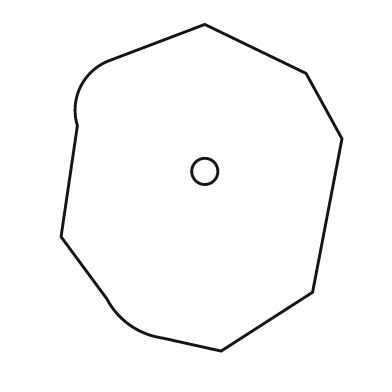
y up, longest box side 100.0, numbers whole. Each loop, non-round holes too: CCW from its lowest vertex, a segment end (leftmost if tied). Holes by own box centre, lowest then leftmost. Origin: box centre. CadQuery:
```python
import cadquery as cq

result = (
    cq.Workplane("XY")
    .moveTo(6.0, -50.0)
    .lineTo(34.0, -32.0)
    .lineTo(43.0, 15.0)
    .lineTo(32.0, 35.0)
    .lineTo(1.0, 50.0)
    .lineTo(-28.0, 39.0)
    .threePointArc((-37.0, 31.0), (-38.0, 19.0))
    .lineTo(-43.0, -15.0)
    .lineTo(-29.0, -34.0)
    .threePointArc((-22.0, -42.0), (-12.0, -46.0))
    .close()
    .moveTo(1.0, 5.0)
    .circle(4.0)
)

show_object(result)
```